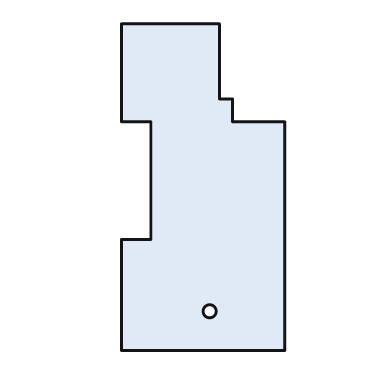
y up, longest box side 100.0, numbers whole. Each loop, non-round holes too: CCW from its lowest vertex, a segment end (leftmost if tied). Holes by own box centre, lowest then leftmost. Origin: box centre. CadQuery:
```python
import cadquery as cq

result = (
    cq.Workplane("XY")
    .moveTo(-25.0, -50.0)
    .lineTo(25.0, -50.0)
    .lineTo(25.0, 20.0)
    .lineTo(9.0, 20.0)
    .lineTo(9.0, 27.0)
    .lineTo(5.0, 27.0)
    .lineTo(5.0, 50.0)
    .lineTo(-25.0, 50.0)
    .lineTo(-25.0, 20.0)
    .lineTo(-16.0, 20.0)
    .lineTo(-16.0, -16.0)
    .lineTo(-25.0, -16.0)
    .close()
    .moveTo(2.0, -38.0)
    .circle(2.0)
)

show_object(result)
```